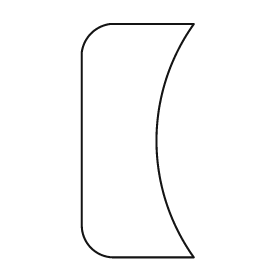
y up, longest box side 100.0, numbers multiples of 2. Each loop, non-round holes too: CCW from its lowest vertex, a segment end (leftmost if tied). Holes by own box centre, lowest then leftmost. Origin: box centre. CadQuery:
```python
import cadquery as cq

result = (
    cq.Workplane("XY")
    .moveTo(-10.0, -50.0)
    .lineTo(24.0, -50.0)
    .threePointArc((8.0, 0.0), (24.0, 50.0))
    .lineTo(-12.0, 50.0)
    .threePointArc((-20.0, 46.0), (-24.0, 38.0))
    .lineTo(-24.0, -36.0)
    .threePointArc((-20.0, -46.0), (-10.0, -50.0))
    .close()
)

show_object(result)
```